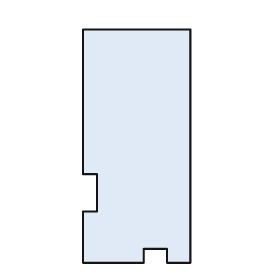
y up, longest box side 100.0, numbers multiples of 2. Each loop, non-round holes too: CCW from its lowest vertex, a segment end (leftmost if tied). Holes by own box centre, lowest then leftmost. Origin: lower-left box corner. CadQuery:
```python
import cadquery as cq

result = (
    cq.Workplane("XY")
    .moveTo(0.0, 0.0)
    .lineTo(26.0, 0.0)
    .lineTo(26.0, 6.0)
    .lineTo(36.0, 6.0)
    .lineTo(36.0, 0.0)
    .lineTo(46.0, 0.0)
    .lineTo(46.0, 100.0)
    .lineTo(0.0, 100.0)
    .lineTo(0.0, 38.0)
    .lineTo(6.0, 38.0)
    .lineTo(6.0, 22.0)
    .lineTo(0.0, 22.0)
    .close()
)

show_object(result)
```